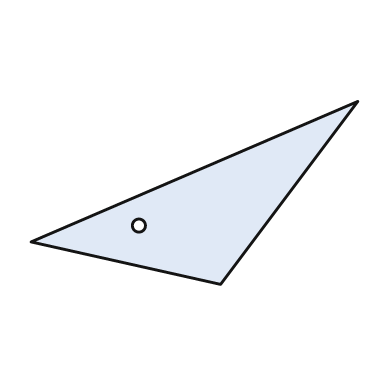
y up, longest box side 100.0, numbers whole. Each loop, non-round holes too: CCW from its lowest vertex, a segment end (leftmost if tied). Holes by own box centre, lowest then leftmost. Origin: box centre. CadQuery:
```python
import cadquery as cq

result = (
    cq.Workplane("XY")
    .moveTo(8.0, -28.0)
    .lineTo(50.0, 28.0)
    .lineTo(-50.0, -15.0)
    .close()
    .moveTo(-17.0, -10.0)
    .circle(2.0)
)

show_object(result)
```